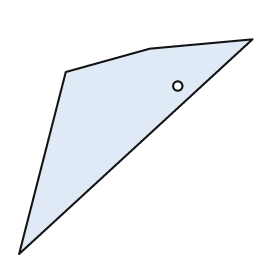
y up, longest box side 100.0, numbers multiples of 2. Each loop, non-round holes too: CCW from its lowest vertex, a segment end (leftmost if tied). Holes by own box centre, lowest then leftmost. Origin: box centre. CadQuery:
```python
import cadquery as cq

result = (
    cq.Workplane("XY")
    .moveTo(-50.0, -46.0)
    .lineTo(50.0, 46.0)
    .lineTo(6.0, 42.0)
    .lineTo(-30.0, 32.0)
    .close()
    .moveTo(18.0, 26.0)
    .circle(2.0)
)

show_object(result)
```